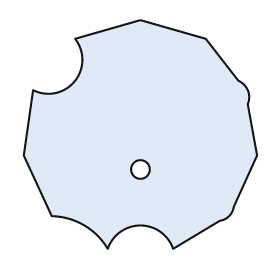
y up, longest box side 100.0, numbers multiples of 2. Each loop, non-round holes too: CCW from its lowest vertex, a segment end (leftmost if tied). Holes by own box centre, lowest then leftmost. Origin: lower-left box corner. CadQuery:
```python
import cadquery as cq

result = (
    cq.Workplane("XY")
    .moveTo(36.0, 0.0)
    .threePointArc((50.0, 10.0), (64.0, 0.0))
    .lineTo(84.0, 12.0)
    .threePointArc((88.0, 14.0), (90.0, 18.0))
    .lineTo(100.0, 40.0)
    .lineTo(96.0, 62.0)
    .threePointArc((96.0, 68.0), (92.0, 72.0))
    .lineTo(78.0, 90.0)
    .lineTo(50.0, 98.0)
    .lineTo(22.0, 90.0)
    .threePointArc((22.0, 72.0), (4.0, 68.0))
    .lineTo(0.0, 40.0)
    .lineTo(12.0, 14.0)
    .threePointArc((26.0, 10.0), (36.0, 0.0))
    .close()
    .moveTo(50.0, 34.0)
    .circle(4.0)
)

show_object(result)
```